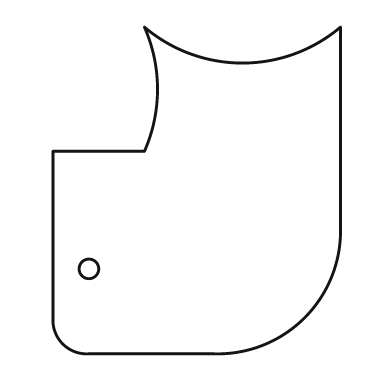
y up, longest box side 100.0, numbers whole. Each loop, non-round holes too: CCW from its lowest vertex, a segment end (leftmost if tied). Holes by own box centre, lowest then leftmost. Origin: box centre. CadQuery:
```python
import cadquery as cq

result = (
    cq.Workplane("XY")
    .moveTo(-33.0, -50.0)
    .lineTo(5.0, -50.0)
    .threePointArc((33.0, -39.0), (44.0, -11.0))
    .lineTo(44.0, 50.0)
    .threePointArc((14.0, 39.0), (-16.0, 50.0))
    .threePointArc((-12.0, 31.0), (-16.0, 12.0))
    .lineTo(-44.0, 12.0)
    .lineTo(-44.0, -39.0)
    .threePointArc((-41.0, -47.0), (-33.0, -50.0))
    .close()
    .moveTo(-33.0, -24.0)
    .circle(3.0)
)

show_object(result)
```